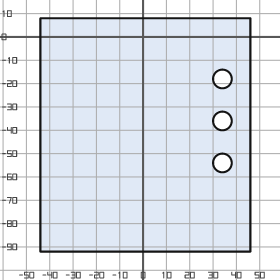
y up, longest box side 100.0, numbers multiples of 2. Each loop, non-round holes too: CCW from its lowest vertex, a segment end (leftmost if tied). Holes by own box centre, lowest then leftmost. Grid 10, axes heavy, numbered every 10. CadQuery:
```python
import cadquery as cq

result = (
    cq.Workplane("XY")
    .moveTo(-44.0, -92.0)
    .lineTo(46.0, -92.0)
    .lineTo(46.0, 8.0)
    .lineTo(-44.0, 8.0)
    .close()
    .moveTo(34.0, -54.0)
    .circle(4.0)
    .moveTo(34.0, -36.0)
    .circle(4.0)
    .moveTo(34.0, -18.0)
    .circle(4.0)
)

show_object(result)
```